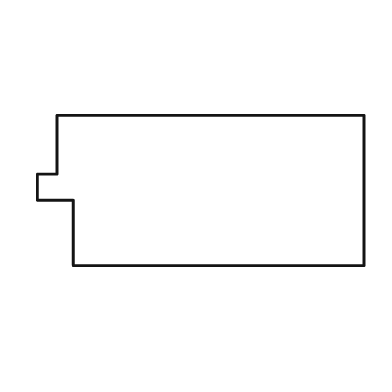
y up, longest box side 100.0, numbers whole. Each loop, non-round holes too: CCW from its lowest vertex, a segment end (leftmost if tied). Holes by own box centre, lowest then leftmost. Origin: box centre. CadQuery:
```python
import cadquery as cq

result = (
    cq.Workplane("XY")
    .moveTo(-39.0, -23.0)
    .lineTo(50.0, -23.0)
    .lineTo(50.0, 23.0)
    .lineTo(-44.0, 23.0)
    .lineTo(-44.0, 5.0)
    .lineTo(-50.0, 5.0)
    .lineTo(-50.0, -3.0)
    .lineTo(-39.0, -3.0)
    .close()
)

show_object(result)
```